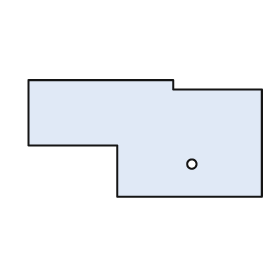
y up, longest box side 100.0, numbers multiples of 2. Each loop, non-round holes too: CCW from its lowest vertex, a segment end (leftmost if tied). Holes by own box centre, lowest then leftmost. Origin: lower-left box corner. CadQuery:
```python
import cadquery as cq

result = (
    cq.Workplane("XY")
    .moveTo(38.0, 0.0)
    .lineTo(100.0, 0.0)
    .lineTo(100.0, 46.0)
    .lineTo(62.0, 46.0)
    .lineTo(62.0, 50.0)
    .lineTo(0.0, 50.0)
    .lineTo(0.0, 22.0)
    .lineTo(38.0, 22.0)
    .close()
    .moveTo(70.0, 14.0)
    .circle(2.0)
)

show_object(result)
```